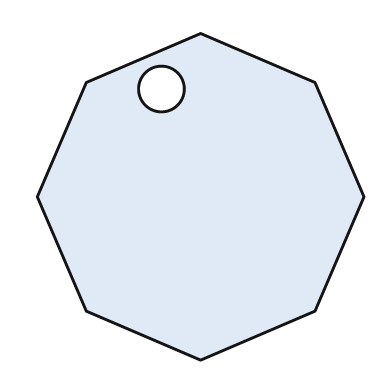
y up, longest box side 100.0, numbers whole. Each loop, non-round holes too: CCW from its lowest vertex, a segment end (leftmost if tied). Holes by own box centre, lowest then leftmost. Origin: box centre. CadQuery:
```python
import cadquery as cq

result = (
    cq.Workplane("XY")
    .moveTo(0.0, -50.0)
    .lineTo(35.0, -35.0)
    .lineTo(50.0, 0.0)
    .lineTo(35.0, 35.0)
    .lineTo(0.0, 50.0)
    .lineTo(-35.0, 35.0)
    .lineTo(-50.0, 0.0)
    .lineTo(-35.0, -35.0)
    .close()
    .moveTo(-12.0, 33.0)
    .circle(7.0)
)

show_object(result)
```